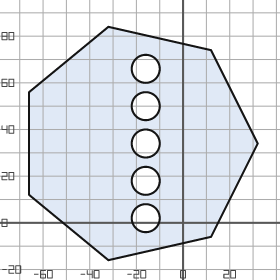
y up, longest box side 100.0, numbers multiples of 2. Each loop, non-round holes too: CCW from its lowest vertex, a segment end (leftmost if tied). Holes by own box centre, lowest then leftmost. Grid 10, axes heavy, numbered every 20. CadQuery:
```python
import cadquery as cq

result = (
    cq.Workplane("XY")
    .moveTo(-32.0, -16.0)
    .lineTo(12.0, -6.0)
    .lineTo(32.0, 34.0)
    .lineTo(12.0, 74.0)
    .lineTo(-32.0, 84.0)
    .lineTo(-66.0, 56.0)
    .lineTo(-66.0, 12.0)
    .close()
    .moveTo(-16.0, 2.0)
    .circle(6.0)
    .moveTo(-16.0, 18.0)
    .circle(6.0)
    .moveTo(-16.0, 34.0)
    .circle(6.0)
    .moveTo(-16.0, 50.0)
    .circle(6.0)
    .moveTo(-16.0, 66.0)
    .circle(6.0)
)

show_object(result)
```